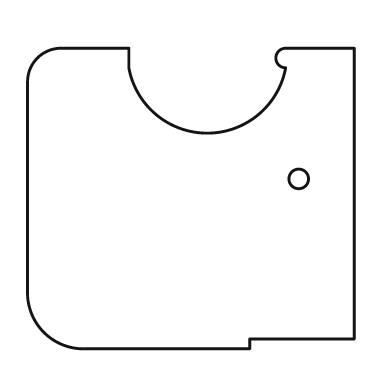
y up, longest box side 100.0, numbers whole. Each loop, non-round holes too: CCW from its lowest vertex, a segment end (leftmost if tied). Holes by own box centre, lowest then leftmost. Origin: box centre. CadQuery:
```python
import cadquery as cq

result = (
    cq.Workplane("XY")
    .moveTo(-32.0, -46.0)
    .lineTo(18.0, -46.0)
    .lineTo(18.0, -43.0)
    .lineTo(50.0, -43.0)
    .lineTo(50.0, 46.0)
    .lineTo(29.0, 46.0)
    .threePointArc((26.0, 43.0), (29.0, 40.0))
    .threePointArc((5.0, 20.0), (-19.0, 40.0))
    .lineTo(-19.0, 46.0)
    .lineTo(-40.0, 46.0)
    .threePointArc((-47.0, 43.0), (-50.0, 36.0))
    .lineTo(-50.0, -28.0)
    .threePointArc((-45.0, -41.0), (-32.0, -46.0))
    .close()
    .moveTo(33.0, 6.0)
    .circle(3.0)
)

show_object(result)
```